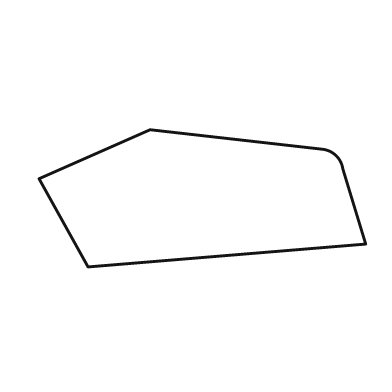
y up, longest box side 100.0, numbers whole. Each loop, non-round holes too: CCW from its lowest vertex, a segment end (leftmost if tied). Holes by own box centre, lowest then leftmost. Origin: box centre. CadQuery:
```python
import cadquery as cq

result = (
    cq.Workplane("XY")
    .moveTo(-35.0, -21.0)
    .lineTo(50.0, -14.0)
    .lineTo(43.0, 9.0)
    .threePointArc((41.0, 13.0), (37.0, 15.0))
    .lineTo(-16.0, 21.0)
    .lineTo(-50.0, 6.0)
    .close()
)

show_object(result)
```